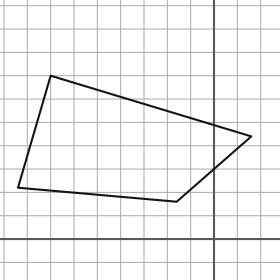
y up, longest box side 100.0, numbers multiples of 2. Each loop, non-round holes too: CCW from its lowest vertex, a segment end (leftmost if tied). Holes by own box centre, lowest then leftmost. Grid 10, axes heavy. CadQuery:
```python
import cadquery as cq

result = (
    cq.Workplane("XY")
    .moveTo(-16.0, 16.0)
    .lineTo(16.0, 44.0)
    .lineTo(-70.0, 70.0)
    .lineTo(-84.0, 22.0)
    .close()
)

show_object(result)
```